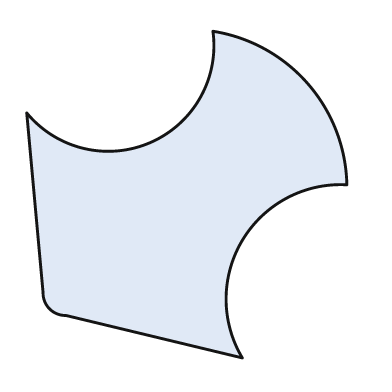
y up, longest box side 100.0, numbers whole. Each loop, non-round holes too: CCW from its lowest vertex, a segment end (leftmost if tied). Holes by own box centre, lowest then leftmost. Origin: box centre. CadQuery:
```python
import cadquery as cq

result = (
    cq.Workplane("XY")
    .moveTo(17.0, -50.0)
    .threePointArc((17.0, -14.0), (49.0, 3.0))
    .threePointArc((37.0, 34.0), (8.0, 50.0))
    .threePointArc((-11.0, 16.0), (-49.0, 25.0))
    .lineTo(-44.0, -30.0)
    .threePointArc((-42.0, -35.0), (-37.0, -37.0))
    .close()
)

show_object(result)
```